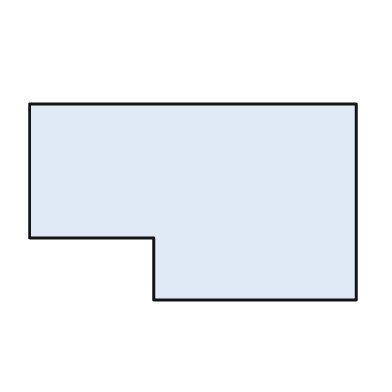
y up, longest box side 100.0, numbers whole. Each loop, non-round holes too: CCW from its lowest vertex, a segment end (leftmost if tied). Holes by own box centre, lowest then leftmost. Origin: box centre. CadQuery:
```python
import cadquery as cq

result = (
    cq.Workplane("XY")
    .moveTo(-12.0, -30.0)
    .lineTo(50.0, -30.0)
    .lineTo(50.0, 30.0)
    .lineTo(-50.0, 30.0)
    .lineTo(-50.0, -11.0)
    .lineTo(-12.0, -11.0)
    .close()
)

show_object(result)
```